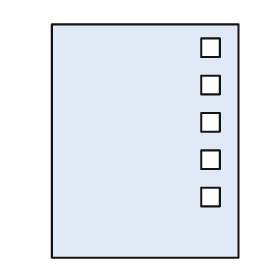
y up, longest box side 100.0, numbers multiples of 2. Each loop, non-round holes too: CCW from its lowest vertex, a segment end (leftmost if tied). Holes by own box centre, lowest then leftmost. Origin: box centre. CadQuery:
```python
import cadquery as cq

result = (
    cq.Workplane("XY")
    .moveTo(-40.0, -50.0)
    .lineTo(40.0, -50.0)
    .lineTo(40.0, 50.0)
    .lineTo(-40.0, 50.0)
    .close()
    .moveTo(24.0, -28.0)
    .lineTo(32.0, -28.0)
    .lineTo(32.0, -20.0)
    .lineTo(24.0, -20.0)
    .close()
    .moveTo(24.0, -12.0)
    .lineTo(32.0, -12.0)
    .lineTo(32.0, -4.0)
    .lineTo(24.0, -4.0)
    .close()
    .moveTo(24.0, 4.0)
    .lineTo(32.0, 4.0)
    .lineTo(32.0, 12.0)
    .lineTo(24.0, 12.0)
    .close()
    .moveTo(24.0, 20.0)
    .lineTo(32.0, 20.0)
    .lineTo(32.0, 28.0)
    .lineTo(24.0, 28.0)
    .close()
    .moveTo(24.0, 36.0)
    .lineTo(32.0, 36.0)
    .lineTo(32.0, 44.0)
    .lineTo(24.0, 44.0)
    .close()
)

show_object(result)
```